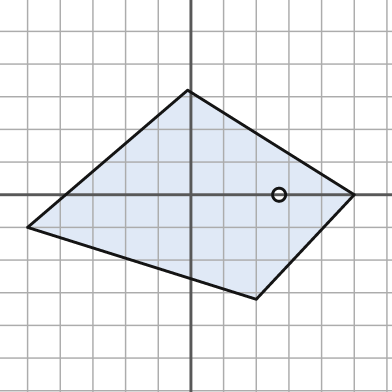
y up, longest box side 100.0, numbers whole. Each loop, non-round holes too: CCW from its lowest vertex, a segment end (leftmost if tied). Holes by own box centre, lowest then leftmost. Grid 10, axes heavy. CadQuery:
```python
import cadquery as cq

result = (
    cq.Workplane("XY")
    .moveTo(20.0, -32.0)
    .lineTo(50.0, 0.0)
    .lineTo(-1.0, 32.0)
    .lineTo(-50.0, -10.0)
    .close()
    .moveTo(27.0, 0.0)
    .circle(2.0)
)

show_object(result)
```